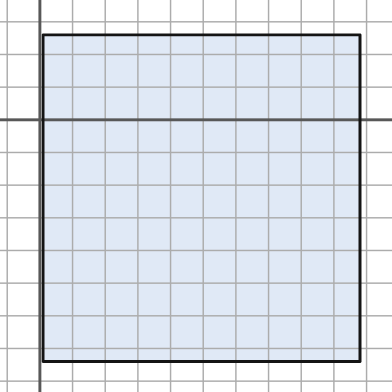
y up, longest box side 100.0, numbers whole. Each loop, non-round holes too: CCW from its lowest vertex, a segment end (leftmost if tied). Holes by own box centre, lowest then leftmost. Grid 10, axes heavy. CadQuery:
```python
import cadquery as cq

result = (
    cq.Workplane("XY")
    .moveTo(1.0, -74.0)
    .lineTo(98.0, -74.0)
    .lineTo(98.0, 26.0)
    .lineTo(1.0, 26.0)
    .close()
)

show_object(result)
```